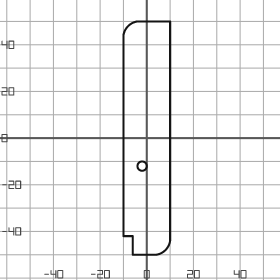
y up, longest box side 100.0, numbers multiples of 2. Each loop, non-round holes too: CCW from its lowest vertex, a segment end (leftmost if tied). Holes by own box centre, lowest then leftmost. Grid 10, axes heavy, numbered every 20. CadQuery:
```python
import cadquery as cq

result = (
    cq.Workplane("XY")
    .moveTo(-6.0, -50.0)
    .lineTo(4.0, -50.0)
    .threePointArc((8.0, -48.0), (10.0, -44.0))
    .lineTo(10.0, 50.0)
    .lineTo(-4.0, 50.0)
    .threePointArc((-8.0, 48.0), (-10.0, 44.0))
    .lineTo(-10.0, -42.0)
    .lineTo(-6.0, -42.0)
    .close()
    .moveTo(-2.0, -12.0)
    .circle(2.0)
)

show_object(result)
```